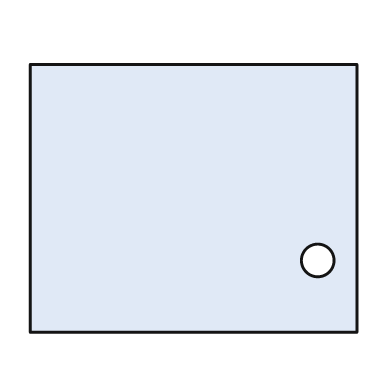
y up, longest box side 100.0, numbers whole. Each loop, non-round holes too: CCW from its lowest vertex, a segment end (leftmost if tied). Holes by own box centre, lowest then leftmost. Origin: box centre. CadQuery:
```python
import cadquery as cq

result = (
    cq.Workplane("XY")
    .moveTo(-50.0, -41.0)
    .lineTo(50.0, -41.0)
    .lineTo(50.0, 41.0)
    .lineTo(-50.0, 41.0)
    .close()
    .moveTo(38.0, -19.0)
    .circle(5.0)
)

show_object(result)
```